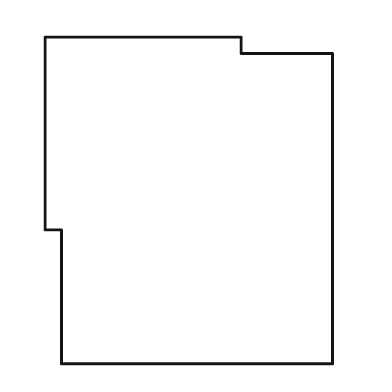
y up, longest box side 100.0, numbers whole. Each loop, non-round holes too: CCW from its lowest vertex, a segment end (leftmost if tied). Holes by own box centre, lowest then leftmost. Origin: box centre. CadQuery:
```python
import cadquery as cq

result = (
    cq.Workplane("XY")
    .moveTo(-39.0, -50.0)
    .lineTo(44.0, -50.0)
    .lineTo(44.0, 45.0)
    .lineTo(16.0, 45.0)
    .lineTo(16.0, 50.0)
    .lineTo(-44.0, 50.0)
    .lineTo(-44.0, -9.0)
    .lineTo(-39.0, -9.0)
    .close()
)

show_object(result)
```